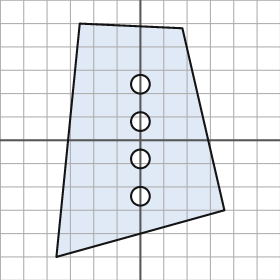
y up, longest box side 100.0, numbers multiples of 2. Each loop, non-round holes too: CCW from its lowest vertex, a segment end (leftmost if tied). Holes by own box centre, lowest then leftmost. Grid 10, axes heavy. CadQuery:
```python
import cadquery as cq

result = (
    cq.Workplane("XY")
    .moveTo(-36.0, -50.0)
    .lineTo(36.0, -30.0)
    .lineTo(18.0, 48.0)
    .lineTo(-26.0, 50.0)
    .close()
    .moveTo(0.0, -24.0)
    .circle(4.0)
    .moveTo(0.0, -8.0)
    .circle(4.0)
    .moveTo(0.0, 8.0)
    .circle(4.0)
    .moveTo(0.0, 24.0)
    .circle(4.0)
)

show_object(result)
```